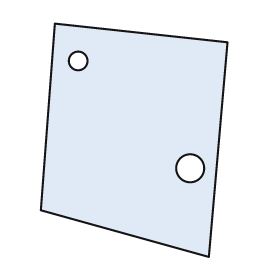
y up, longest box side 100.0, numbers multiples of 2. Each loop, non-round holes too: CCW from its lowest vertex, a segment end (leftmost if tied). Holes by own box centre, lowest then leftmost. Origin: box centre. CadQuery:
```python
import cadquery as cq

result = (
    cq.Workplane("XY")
    .moveTo(32.0, -50.0)
    .lineTo(40.0, 42.0)
    .lineTo(-34.0, 50.0)
    .lineTo(-40.0, -30.0)
    .close()
    .moveTo(24.0, -12.0)
    .circle(6.0)
    .moveTo(-24.0, 34.0)
    .circle(4.0)
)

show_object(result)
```